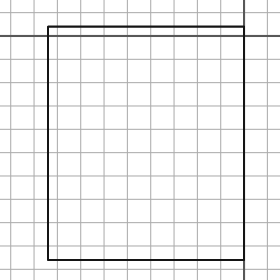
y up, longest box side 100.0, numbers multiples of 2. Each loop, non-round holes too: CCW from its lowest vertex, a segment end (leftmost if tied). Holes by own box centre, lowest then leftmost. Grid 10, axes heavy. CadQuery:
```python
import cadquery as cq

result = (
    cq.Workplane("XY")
    .moveTo(-84.0, -96.0)
    .lineTo(0.0, -96.0)
    .lineTo(0.0, 4.0)
    .lineTo(-84.0, 4.0)
    .close()
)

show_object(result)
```